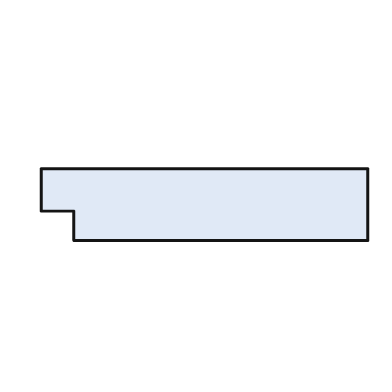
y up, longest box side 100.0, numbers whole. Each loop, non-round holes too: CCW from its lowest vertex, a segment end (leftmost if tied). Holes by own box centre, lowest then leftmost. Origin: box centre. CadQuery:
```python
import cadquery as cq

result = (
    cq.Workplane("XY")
    .moveTo(-40.0, -11.0)
    .lineTo(50.0, -11.0)
    .lineTo(50.0, 11.0)
    .lineTo(-50.0, 11.0)
    .lineTo(-50.0, -2.0)
    .lineTo(-40.0, -2.0)
    .close()
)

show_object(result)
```